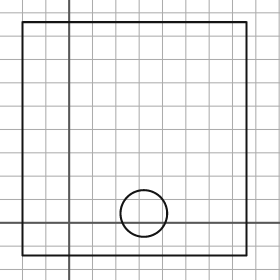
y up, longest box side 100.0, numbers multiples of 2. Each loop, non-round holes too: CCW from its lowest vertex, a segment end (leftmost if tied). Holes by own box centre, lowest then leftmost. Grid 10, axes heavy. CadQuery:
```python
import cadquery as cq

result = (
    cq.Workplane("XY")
    .moveTo(-20.0, -14.0)
    .lineTo(76.0, -14.0)
    .lineTo(76.0, 86.0)
    .lineTo(-20.0, 86.0)
    .close()
    .moveTo(32.0, 4.0)
    .circle(10.0)
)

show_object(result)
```